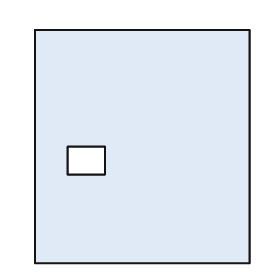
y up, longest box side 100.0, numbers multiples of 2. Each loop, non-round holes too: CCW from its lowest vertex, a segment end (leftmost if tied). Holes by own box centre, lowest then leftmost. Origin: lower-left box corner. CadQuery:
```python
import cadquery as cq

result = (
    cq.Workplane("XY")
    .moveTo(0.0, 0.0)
    .lineTo(92.0, 0.0)
    .lineTo(92.0, 100.0)
    .lineTo(0.0, 100.0)
    .close()
    .moveTo(14.0, 38.0)
    .lineTo(30.0, 38.0)
    .lineTo(30.0, 50.0)
    .lineTo(14.0, 50.0)
    .close()
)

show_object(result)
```